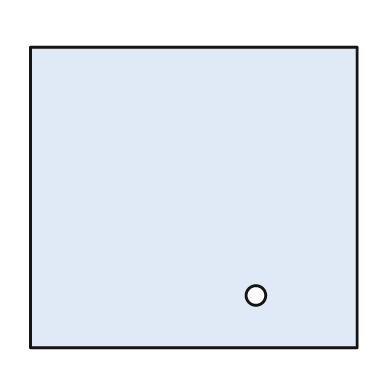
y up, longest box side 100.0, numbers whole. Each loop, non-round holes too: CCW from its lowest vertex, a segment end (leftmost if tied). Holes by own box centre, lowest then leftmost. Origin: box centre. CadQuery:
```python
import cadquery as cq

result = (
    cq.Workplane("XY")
    .moveTo(-50.0, -46.0)
    .lineTo(50.0, -46.0)
    .lineTo(50.0, 46.0)
    .lineTo(-50.0, 46.0)
    .close()
    .moveTo(19.0, -30.0)
    .circle(3.0)
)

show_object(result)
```